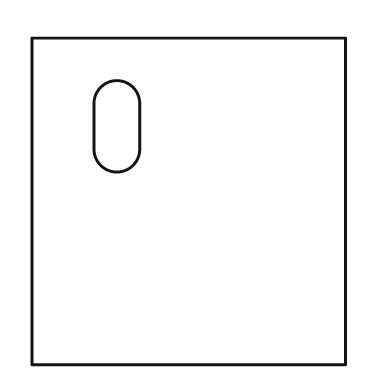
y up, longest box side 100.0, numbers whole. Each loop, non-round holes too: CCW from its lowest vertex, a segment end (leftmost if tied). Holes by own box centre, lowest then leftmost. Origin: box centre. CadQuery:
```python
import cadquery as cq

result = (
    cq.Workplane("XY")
    .moveTo(-48.0, -50.0)
    .lineTo(48.0, -50.0)
    .lineTo(48.0, 50.0)
    .lineTo(-48.0, 50.0)
    .close()
    .moveTo(-29.0, 16.0)
    .threePointArc((-22.0, 9.0), (-15.0, 16.0))
    .lineTo(-15.0, 30.0)
    .threePointArc((-22.0, 37.0), (-29.0, 30.0))
    .close()
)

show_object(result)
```